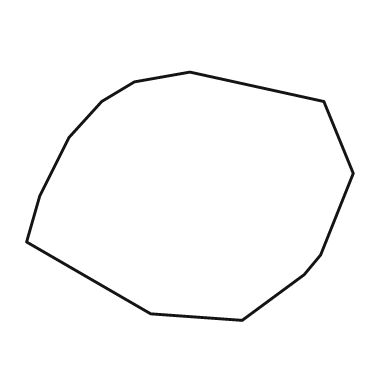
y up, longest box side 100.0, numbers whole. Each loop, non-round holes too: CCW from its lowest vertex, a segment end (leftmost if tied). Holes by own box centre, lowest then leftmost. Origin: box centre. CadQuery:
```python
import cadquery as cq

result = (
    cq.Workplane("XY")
    .moveTo(16.0, -38.0)
    .lineTo(35.0, -24.0)
    .lineTo(40.0, -18.0)
    .lineTo(50.0, 7.0)
    .lineTo(41.0, 29.0)
    .lineTo(0.0, 38.0)
    .lineTo(-17.0, 35.0)
    .lineTo(-27.0, 29.0)
    .lineTo(-37.0, 18.0)
    .lineTo(-46.0, 0.0)
    .lineTo(-50.0, -14.0)
    .lineTo(-12.0, -36.0)
    .close()
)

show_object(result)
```